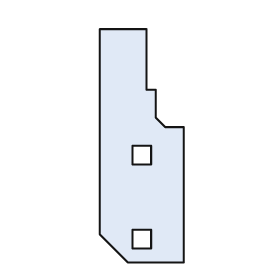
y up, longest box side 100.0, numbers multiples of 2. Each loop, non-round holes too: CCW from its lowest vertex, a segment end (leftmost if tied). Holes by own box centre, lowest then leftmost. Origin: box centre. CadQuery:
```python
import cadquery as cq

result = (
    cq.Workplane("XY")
    .moveTo(-6.0, -50.0)
    .lineTo(18.0, -50.0)
    .lineTo(18.0, 8.0)
    .lineTo(10.0, 8.0)
    .lineTo(6.0, 12.0)
    .lineTo(6.0, 24.0)
    .lineTo(2.0, 24.0)
    .lineTo(2.0, 50.0)
    .lineTo(-18.0, 50.0)
    .lineTo(-18.0, -38.0)
    .close()
    .moveTo(-4.0, -44.0)
    .lineTo(4.0, -44.0)
    .lineTo(4.0, -36.0)
    .lineTo(-4.0, -36.0)
    .close()
    .moveTo(-4.0, -8.0)
    .lineTo(4.0, -8.0)
    .lineTo(4.0, 0.0)
    .lineTo(-4.0, 0.0)
    .close()
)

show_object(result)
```